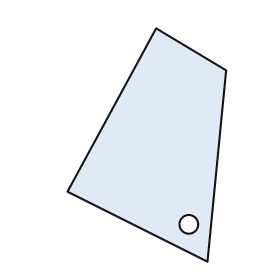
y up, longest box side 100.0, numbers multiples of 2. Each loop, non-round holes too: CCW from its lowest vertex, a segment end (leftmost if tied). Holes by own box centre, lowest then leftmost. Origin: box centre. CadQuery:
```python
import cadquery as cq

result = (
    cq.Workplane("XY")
    .moveTo(26.0, -50.0)
    .lineTo(34.0, 32.0)
    .lineTo(4.0, 50.0)
    .lineTo(-34.0, -20.0)
    .close()
    .moveTo(18.0, -34.0)
    .circle(4.0)
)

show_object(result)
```